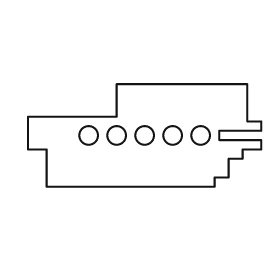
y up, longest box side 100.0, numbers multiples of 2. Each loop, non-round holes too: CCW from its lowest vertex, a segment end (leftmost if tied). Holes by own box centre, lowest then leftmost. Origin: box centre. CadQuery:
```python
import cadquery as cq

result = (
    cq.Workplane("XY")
    .moveTo(-42.0, -22.0)
    .lineTo(30.0, -22.0)
    .lineTo(30.0, -18.0)
    .lineTo(36.0, -18.0)
    .lineTo(36.0, -10.0)
    .lineTo(42.0, -10.0)
    .lineTo(42.0, -6.0)
    .lineTo(50.0, -6.0)
    .lineTo(50.0, -2.0)
    .lineTo(32.0, -2.0)
    .lineTo(32.0, 2.0)
    .lineTo(50.0, 2.0)
    .lineTo(50.0, 6.0)
    .lineTo(44.0, 6.0)
    .lineTo(44.0, 22.0)
    .lineTo(-12.0, 22.0)
    .lineTo(-12.0, 8.0)
    .lineTo(-50.0, 8.0)
    .lineTo(-50.0, -6.0)
    .lineTo(-42.0, -6.0)
    .close()
    .moveTo(-24.0, 0.0)
    .circle(4.0)
    .moveTo(-12.0, 0.0)
    .circle(4.0)
    .moveTo(0.0, 0.0)
    .circle(4.0)
    .moveTo(12.0, 0.0)
    .circle(4.0)
    .moveTo(24.0, 0.0)
    .circle(4.0)
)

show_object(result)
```